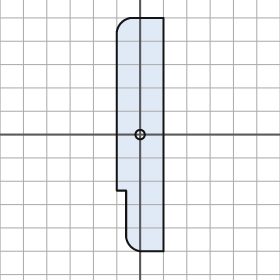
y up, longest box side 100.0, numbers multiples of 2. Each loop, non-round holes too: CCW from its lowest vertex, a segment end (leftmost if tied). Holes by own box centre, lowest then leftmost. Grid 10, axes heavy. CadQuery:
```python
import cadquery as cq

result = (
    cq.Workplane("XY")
    .moveTo(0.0, -50.0)
    .lineTo(10.0, -50.0)
    .lineTo(10.0, 50.0)
    .lineTo(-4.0, 50.0)
    .threePointArc((-8.0, 48.0), (-10.0, 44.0))
    .lineTo(-10.0, -24.0)
    .lineTo(-6.0, -24.0)
    .lineTo(-6.0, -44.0)
    .threePointArc((-4.0, -48.0), (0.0, -50.0))
    .close()
    .moveTo(0.0, 0.0)
    .circle(2.0)
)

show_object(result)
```